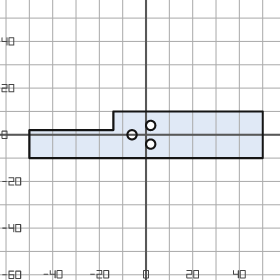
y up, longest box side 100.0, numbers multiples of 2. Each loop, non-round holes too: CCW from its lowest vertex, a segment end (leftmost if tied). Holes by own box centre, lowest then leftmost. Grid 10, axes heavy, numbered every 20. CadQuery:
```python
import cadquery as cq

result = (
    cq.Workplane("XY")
    .moveTo(-50.0, -10.0)
    .lineTo(50.0, -10.0)
    .lineTo(50.0, 10.0)
    .lineTo(-14.0, 10.0)
    .lineTo(-14.0, 2.0)
    .lineTo(-50.0, 2.0)
    .close()
    .moveTo(2.0, -4.0)
    .circle(2.0)
    .moveTo(-6.0, 0.0)
    .circle(2.0)
    .moveTo(2.0, 4.0)
    .circle(2.0)
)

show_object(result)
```